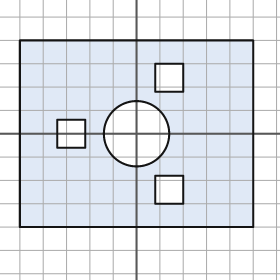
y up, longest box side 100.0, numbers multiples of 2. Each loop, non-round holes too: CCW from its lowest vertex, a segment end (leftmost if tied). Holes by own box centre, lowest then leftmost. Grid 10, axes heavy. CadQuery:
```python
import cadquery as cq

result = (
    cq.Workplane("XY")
    .moveTo(-50.0, -40.0)
    .lineTo(50.0, -40.0)
    .lineTo(50.0, 40.0)
    .lineTo(-50.0, 40.0)
    .close()
    .moveTo(8.0, -30.0)
    .lineTo(20.0, -30.0)
    .lineTo(20.0, -18.0)
    .lineTo(8.0, -18.0)
    .close()
    .moveTo(-34.0, -6.0)
    .lineTo(-22.0, -6.0)
    .lineTo(-22.0, 6.0)
    .lineTo(-34.0, 6.0)
    .close()
    .moveTo(0.0, 0.0)
    .circle(14.0)
    .moveTo(8.0, 18.0)
    .lineTo(20.0, 18.0)
    .lineTo(20.0, 30.0)
    .lineTo(8.0, 30.0)
    .close()
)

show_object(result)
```